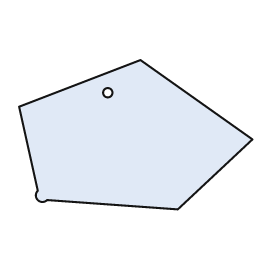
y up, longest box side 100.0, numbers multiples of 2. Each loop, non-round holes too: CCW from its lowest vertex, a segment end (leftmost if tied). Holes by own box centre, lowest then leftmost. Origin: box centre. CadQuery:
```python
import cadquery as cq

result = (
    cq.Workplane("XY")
    .moveTo(18.0, -32.0)
    .lineTo(50.0, -2.0)
    .lineTo(2.0, 32.0)
    .lineTo(-50.0, 12.0)
    .lineTo(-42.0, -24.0)
    .threePointArc((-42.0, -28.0), (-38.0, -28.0))
    .close()
    .moveTo(-12.0, 18.0)
    .circle(2.0)
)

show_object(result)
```